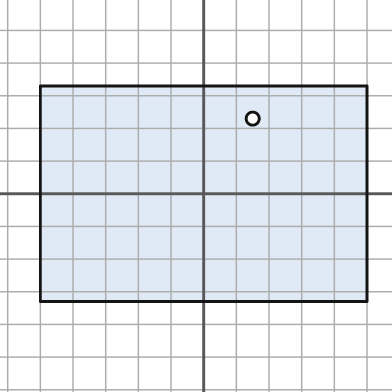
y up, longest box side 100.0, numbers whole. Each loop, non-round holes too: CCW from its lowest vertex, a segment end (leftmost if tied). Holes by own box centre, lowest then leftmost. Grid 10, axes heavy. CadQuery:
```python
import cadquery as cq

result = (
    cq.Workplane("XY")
    .moveTo(-50.0, -33.0)
    .lineTo(50.0, -33.0)
    .lineTo(50.0, 33.0)
    .lineTo(-50.0, 33.0)
    .close()
    .moveTo(15.0, 23.0)
    .circle(2.0)
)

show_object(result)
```